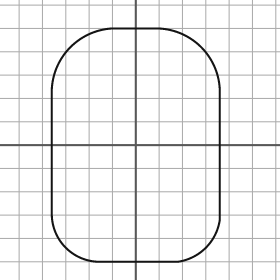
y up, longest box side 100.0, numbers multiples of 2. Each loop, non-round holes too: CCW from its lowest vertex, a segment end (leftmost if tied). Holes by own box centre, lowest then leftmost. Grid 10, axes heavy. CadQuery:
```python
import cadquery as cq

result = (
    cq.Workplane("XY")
    .moveTo(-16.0, -50.0)
    .lineTo(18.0, -50.0)
    .threePointArc((30.0, -44.0), (36.0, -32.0))
    .lineTo(36.0, 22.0)
    .threePointArc((28.0, 42.0), (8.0, 50.0))
    .lineTo(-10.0, 50.0)
    .threePointArc((-28.0, 42.0), (-36.0, 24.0))
    .lineTo(-36.0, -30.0)
    .threePointArc((-30.0, -44.0), (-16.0, -50.0))
    .close()
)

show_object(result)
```